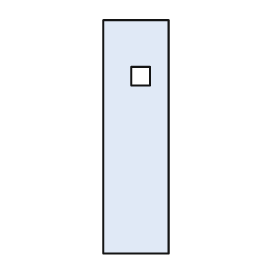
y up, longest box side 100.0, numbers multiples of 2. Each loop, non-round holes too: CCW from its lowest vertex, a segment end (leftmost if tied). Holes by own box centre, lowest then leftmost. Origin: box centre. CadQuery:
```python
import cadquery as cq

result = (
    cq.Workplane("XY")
    .moveTo(-14.0, -50.0)
    .lineTo(14.0, -50.0)
    .lineTo(14.0, 50.0)
    .lineTo(-14.0, 50.0)
    .close()
    .moveTo(-2.0, 22.0)
    .lineTo(6.0, 22.0)
    .lineTo(6.0, 30.0)
    .lineTo(-2.0, 30.0)
    .close()
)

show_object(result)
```